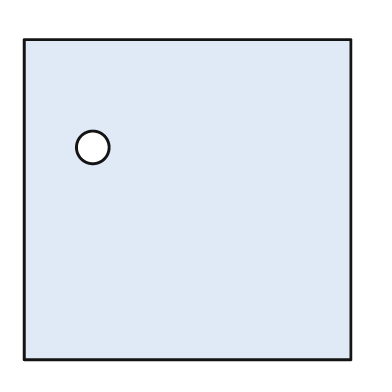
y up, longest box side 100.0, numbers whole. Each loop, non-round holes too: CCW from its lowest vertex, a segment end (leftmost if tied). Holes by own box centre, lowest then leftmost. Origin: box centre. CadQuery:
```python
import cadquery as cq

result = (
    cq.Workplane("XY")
    .moveTo(-50.0, -49.0)
    .lineTo(50.0, -49.0)
    .lineTo(50.0, 49.0)
    .lineTo(-50.0, 49.0)
    .close()
    .moveTo(-29.0, 16.0)
    .circle(5.0)
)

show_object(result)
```